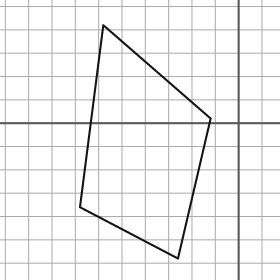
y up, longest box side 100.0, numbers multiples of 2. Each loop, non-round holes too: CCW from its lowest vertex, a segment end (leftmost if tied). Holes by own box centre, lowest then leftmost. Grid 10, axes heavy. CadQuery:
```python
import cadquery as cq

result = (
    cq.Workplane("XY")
    .moveTo(-26.0, -58.0)
    .lineTo(-12.0, 2.0)
    .lineTo(-58.0, 42.0)
    .lineTo(-68.0, -36.0)
    .close()
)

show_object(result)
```